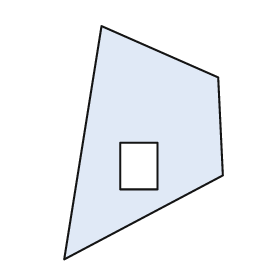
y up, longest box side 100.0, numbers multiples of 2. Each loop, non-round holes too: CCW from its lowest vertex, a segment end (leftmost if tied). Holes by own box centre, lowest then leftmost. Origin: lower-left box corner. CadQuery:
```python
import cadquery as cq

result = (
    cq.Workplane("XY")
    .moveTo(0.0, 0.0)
    .lineTo(68.0, 36.0)
    .lineTo(66.0, 78.0)
    .lineTo(16.0, 100.0)
    .close()
    .moveTo(24.0, 30.0)
    .lineTo(40.0, 30.0)
    .lineTo(40.0, 50.0)
    .lineTo(24.0, 50.0)
    .close()
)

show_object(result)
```